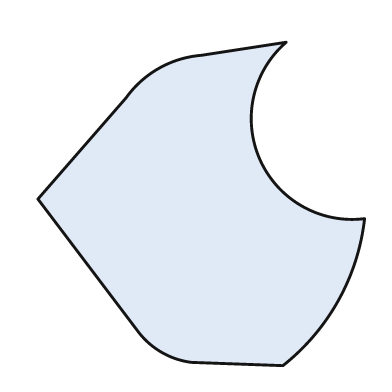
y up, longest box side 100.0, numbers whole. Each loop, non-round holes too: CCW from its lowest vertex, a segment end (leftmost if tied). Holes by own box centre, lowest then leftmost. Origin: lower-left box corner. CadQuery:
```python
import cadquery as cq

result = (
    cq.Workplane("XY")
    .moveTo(75.0, 0.0)
    .threePointArc((92.0, 20.0), (100.0, 45.0))
    .threePointArc((68.0, 63.0), (76.0, 99.0))
    .lineTo(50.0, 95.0)
    .threePointArc((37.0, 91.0), (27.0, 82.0))
    .lineTo(0.0, 51.0)
    .lineTo(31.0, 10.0)
    .threePointArc((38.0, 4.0), (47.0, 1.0))
    .close()
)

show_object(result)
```